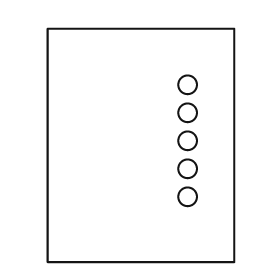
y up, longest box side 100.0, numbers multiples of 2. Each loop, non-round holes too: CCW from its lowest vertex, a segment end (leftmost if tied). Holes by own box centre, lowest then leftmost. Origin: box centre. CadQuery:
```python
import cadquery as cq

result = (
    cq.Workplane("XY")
    .moveTo(-40.0, -50.0)
    .lineTo(40.0, -50.0)
    .lineTo(40.0, 50.0)
    .lineTo(-40.0, 50.0)
    .close()
    .moveTo(20.0, -22.0)
    .circle(4.0)
    .moveTo(20.0, -10.0)
    .circle(4.0)
    .moveTo(20.0, 2.0)
    .circle(4.0)
    .moveTo(20.0, 14.0)
    .circle(4.0)
    .moveTo(20.0, 26.0)
    .circle(4.0)
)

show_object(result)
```